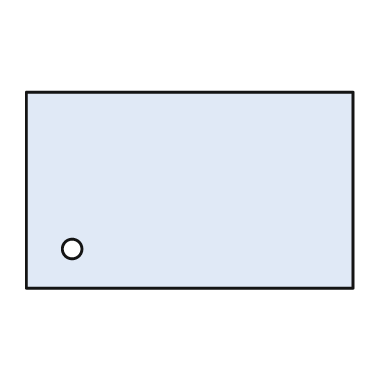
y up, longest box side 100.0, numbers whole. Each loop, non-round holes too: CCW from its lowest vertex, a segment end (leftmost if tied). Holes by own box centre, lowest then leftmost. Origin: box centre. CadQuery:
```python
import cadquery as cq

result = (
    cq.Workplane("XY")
    .moveTo(-50.0, -30.0)
    .lineTo(50.0, -30.0)
    .lineTo(50.0, 30.0)
    .lineTo(-50.0, 30.0)
    .close()
    .moveTo(-36.0, -18.0)
    .circle(3.0)
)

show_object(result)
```